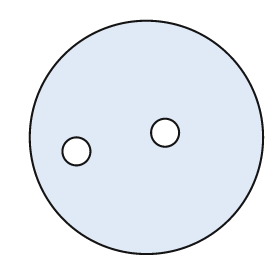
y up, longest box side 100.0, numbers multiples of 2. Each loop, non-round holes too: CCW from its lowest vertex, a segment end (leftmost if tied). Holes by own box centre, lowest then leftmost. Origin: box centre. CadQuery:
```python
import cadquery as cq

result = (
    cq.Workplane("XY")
    .moveTo(0.0, 0.0)
    .circle(50.0)
    .moveTo(-30.0, -6.0)
    .circle(6.0)
    .moveTo(8.0, 2.0)
    .circle(6.0)
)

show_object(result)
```